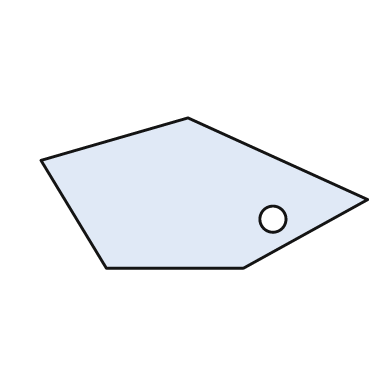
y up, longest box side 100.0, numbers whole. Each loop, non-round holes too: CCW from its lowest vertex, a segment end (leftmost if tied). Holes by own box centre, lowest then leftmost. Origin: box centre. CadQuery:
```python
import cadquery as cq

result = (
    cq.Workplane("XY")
    .moveTo(-30.0, -23.0)
    .lineTo(12.0, -23.0)
    .lineTo(50.0, -2.0)
    .lineTo(-5.0, 23.0)
    .lineTo(-50.0, 10.0)
    .close()
    .moveTo(21.0, -8.0)
    .circle(4.0)
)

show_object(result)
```